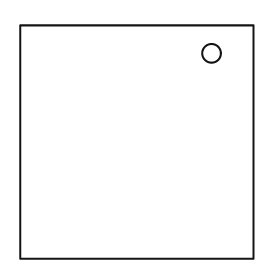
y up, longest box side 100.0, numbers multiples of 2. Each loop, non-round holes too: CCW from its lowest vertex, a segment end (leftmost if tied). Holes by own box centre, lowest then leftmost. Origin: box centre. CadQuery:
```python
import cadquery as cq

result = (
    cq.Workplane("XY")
    .moveTo(-50.0, -50.0)
    .lineTo(50.0, -50.0)
    .lineTo(50.0, 50.0)
    .lineTo(-50.0, 50.0)
    .close()
    .moveTo(32.0, 38.0)
    .circle(4.0)
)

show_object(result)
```